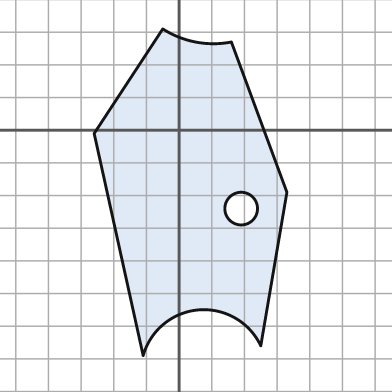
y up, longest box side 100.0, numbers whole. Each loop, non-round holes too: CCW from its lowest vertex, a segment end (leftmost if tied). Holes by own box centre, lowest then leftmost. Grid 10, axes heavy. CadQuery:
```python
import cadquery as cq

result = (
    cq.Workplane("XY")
    .moveTo(-11.0, -69.0)
    .threePointArc((6.0, -55.0), (25.0, -66.0))
    .lineTo(33.0, -19.0)
    .lineTo(16.0, 27.0)
    .threePointArc((5.0, 27.0), (-5.0, 31.0))
    .lineTo(-26.0, -1.0)
    .close()
    .moveTo(19.0, -24.0)
    .circle(5.0)
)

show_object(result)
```